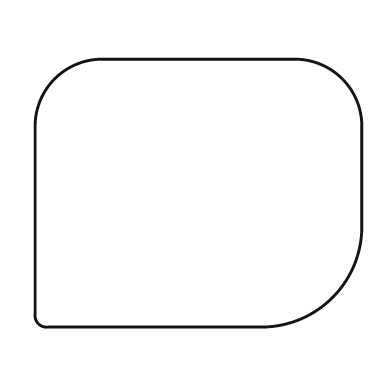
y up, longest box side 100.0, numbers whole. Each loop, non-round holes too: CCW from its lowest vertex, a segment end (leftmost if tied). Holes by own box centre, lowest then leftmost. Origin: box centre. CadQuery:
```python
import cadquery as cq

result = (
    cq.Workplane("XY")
    .moveTo(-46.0, -41.0)
    .lineTo(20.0, -41.0)
    .threePointArc((41.0, -32.0), (50.0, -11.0))
    .lineTo(50.0, 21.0)
    .threePointArc((44.0, 35.0), (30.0, 41.0))
    .lineTo(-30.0, 41.0)
    .threePointArc((-44.0, 35.0), (-50.0, 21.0))
    .lineTo(-50.0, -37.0)
    .threePointArc((-49.0, -40.0), (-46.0, -41.0))
    .close()
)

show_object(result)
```